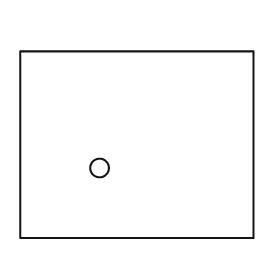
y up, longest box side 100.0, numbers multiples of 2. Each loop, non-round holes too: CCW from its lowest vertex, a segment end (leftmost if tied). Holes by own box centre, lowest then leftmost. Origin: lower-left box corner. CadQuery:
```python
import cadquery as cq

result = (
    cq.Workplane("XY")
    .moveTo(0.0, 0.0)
    .lineTo(100.0, 0.0)
    .lineTo(100.0, 80.0)
    .lineTo(0.0, 80.0)
    .close()
    .moveTo(34.0, 30.0)
    .circle(4.0)
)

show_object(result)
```